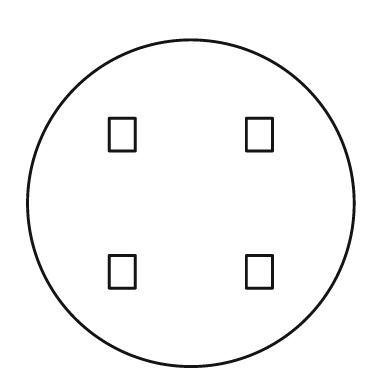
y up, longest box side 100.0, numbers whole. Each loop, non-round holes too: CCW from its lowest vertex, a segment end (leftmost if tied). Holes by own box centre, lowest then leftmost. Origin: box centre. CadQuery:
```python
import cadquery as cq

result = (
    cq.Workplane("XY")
    .moveTo(0.0, 0.0)
    .circle(50.0)
    .moveTo(-25.0, -26.0)
    .lineTo(-17.0, -26.0)
    .lineTo(-17.0, -16.0)
    .lineTo(-25.0, -16.0)
    .close()
    .moveTo(17.0, -26.0)
    .lineTo(25.0, -26.0)
    .lineTo(25.0, -16.0)
    .lineTo(17.0, -16.0)
    .close()
    .moveTo(-25.0, 16.0)
    .lineTo(-17.0, 16.0)
    .lineTo(-17.0, 26.0)
    .lineTo(-25.0, 26.0)
    .close()
    .moveTo(17.0, 16.0)
    .lineTo(25.0, 16.0)
    .lineTo(25.0, 26.0)
    .lineTo(17.0, 26.0)
    .close()
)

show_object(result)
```